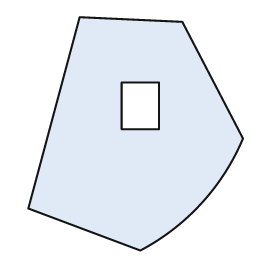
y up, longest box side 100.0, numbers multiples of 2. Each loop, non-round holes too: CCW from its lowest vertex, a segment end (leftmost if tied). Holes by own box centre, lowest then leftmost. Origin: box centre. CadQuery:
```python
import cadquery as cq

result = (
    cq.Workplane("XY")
    .moveTo(2.0, -50.0)
    .threePointArc((28.0, -30.0), (46.0, -2.0))
    .lineTo(20.0, 48.0)
    .lineTo(-24.0, 50.0)
    .lineTo(-46.0, -32.0)
    .close()
    .moveTo(-6.0, 2.0)
    .lineTo(10.0, 2.0)
    .lineTo(10.0, 22.0)
    .lineTo(-6.0, 22.0)
    .close()
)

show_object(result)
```